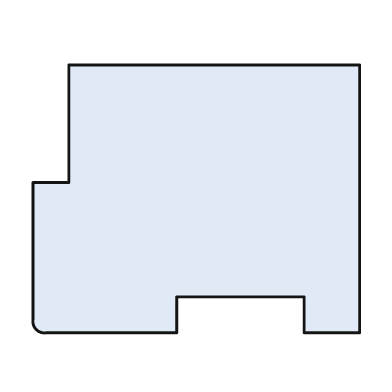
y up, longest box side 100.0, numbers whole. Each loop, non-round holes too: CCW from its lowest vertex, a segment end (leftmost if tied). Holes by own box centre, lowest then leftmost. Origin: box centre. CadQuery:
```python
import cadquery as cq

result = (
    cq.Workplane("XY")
    .moveTo(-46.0, -41.0)
    .lineTo(-6.0, -41.0)
    .lineTo(-6.0, -30.0)
    .lineTo(33.0, -30.0)
    .lineTo(33.0, -41.0)
    .lineTo(50.0, -41.0)
    .lineTo(50.0, 41.0)
    .lineTo(-39.0, 41.0)
    .lineTo(-39.0, 5.0)
    .lineTo(-50.0, 5.0)
    .lineTo(-50.0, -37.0)
    .threePointArc((-49.0, -40.0), (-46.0, -41.0))
    .close()
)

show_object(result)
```